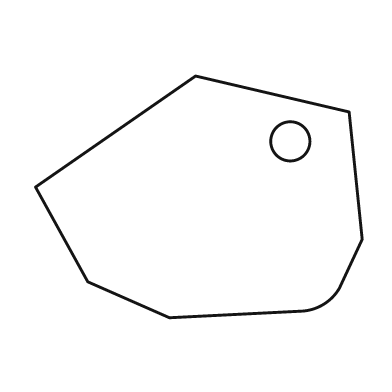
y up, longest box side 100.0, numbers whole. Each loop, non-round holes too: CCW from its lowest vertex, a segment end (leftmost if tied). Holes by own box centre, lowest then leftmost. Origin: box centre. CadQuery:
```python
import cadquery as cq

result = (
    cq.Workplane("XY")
    .moveTo(-9.0, -37.0)
    .lineTo(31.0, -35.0)
    .threePointArc((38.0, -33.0), (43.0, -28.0))
    .lineTo(50.0, -13.0)
    .lineTo(46.0, 26.0)
    .lineTo(-1.0, 37.0)
    .lineTo(-50.0, 3.0)
    .lineTo(-34.0, -26.0)
    .close()
    .moveTo(28.0, 17.0)
    .circle(6.0)
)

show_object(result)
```